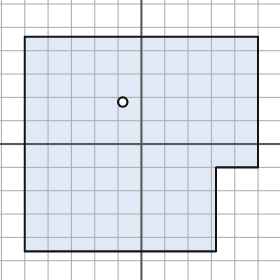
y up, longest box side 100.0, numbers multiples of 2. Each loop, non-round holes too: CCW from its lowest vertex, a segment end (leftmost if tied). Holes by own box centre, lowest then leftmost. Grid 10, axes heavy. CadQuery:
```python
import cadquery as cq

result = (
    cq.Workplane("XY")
    .moveTo(-50.0, -46.0)
    .lineTo(32.0, -46.0)
    .lineTo(32.0, -10.0)
    .lineTo(50.0, -10.0)
    .lineTo(50.0, 46.0)
    .lineTo(-50.0, 46.0)
    .close()
    .moveTo(-8.0, 18.0)
    .circle(2.0)
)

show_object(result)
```